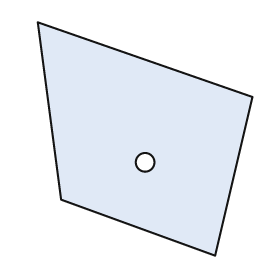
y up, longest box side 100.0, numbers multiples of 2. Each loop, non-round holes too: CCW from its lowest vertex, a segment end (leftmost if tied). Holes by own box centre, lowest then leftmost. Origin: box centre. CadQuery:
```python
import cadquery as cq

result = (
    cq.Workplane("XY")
    .moveTo(30.0, -50.0)
    .lineTo(46.0, 18.0)
    .lineTo(-46.0, 50.0)
    .lineTo(-36.0, -26.0)
    .close()
    .moveTo(0.0, -10.0)
    .circle(4.0)
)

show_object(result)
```